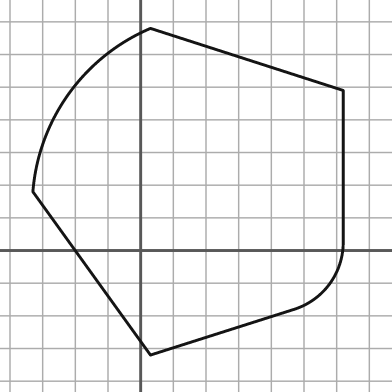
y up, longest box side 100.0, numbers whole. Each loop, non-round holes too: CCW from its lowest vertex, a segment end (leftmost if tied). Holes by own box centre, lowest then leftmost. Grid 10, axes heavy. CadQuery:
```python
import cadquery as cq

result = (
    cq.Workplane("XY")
    .moveTo(3.0, -32.0)
    .lineTo(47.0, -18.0)
    .threePointArc((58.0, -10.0), (62.0, 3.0))
    .lineTo(62.0, 49.0)
    .lineTo(3.0, 68.0)
    .threePointArc((-22.0, 48.0), (-33.0, 18.0))
    .close()
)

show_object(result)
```